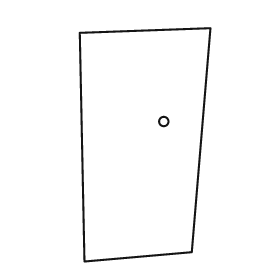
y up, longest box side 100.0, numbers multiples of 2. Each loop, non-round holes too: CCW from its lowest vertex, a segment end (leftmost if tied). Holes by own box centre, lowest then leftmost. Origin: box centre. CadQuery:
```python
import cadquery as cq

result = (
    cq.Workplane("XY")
    .moveTo(-26.0, -50.0)
    .lineTo(20.0, -46.0)
    .lineTo(28.0, 50.0)
    .lineTo(-28.0, 48.0)
    .close()
    .moveTo(8.0, 10.0)
    .circle(2.0)
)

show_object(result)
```